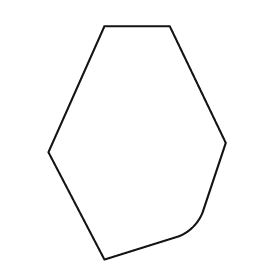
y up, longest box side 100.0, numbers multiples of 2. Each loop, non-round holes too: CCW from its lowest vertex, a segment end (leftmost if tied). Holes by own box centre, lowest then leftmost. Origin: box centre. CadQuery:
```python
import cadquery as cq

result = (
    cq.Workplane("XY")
    .moveTo(-14.0, -50.0)
    .lineTo(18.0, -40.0)
    .threePointArc((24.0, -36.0), (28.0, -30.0))
    .lineTo(38.0, 0.0)
    .lineTo(14.0, 50.0)
    .lineTo(-14.0, 50.0)
    .lineTo(-38.0, -4.0)
    .close()
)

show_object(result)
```